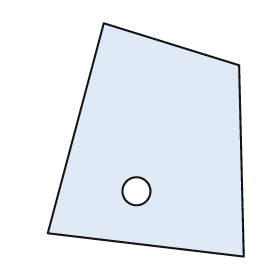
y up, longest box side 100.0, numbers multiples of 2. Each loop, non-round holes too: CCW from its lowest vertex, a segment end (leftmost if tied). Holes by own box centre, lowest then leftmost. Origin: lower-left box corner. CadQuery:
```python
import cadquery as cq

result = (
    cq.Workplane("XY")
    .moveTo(84.0, 0.0)
    .lineTo(82.0, 82.0)
    .lineTo(24.0, 100.0)
    .lineTo(0.0, 10.0)
    .close()
    .moveTo(38.0, 28.0)
    .circle(6.0)
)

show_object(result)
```